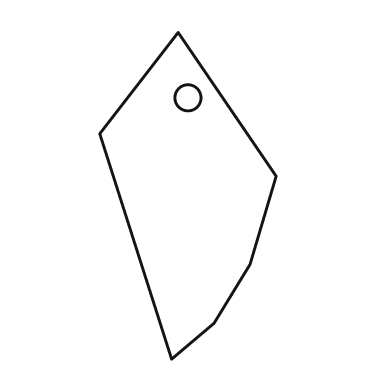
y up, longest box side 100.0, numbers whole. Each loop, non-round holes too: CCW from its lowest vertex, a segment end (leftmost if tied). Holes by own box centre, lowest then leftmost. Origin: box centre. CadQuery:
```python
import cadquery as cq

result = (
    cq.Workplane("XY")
    .moveTo(-5.0, -50.0)
    .lineTo(8.0, -39.0)
    .lineTo(19.0, -21.0)
    .lineTo(27.0, 6.0)
    .lineTo(-3.0, 50.0)
    .lineTo(-27.0, 19.0)
    .close()
    .moveTo(0.0, 30.0)
    .circle(4.0)
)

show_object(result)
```